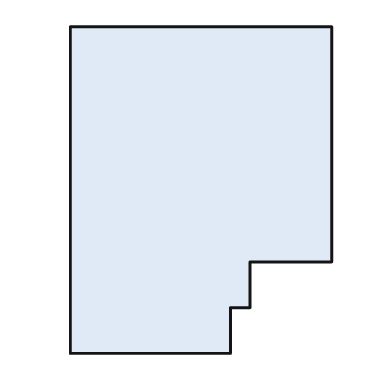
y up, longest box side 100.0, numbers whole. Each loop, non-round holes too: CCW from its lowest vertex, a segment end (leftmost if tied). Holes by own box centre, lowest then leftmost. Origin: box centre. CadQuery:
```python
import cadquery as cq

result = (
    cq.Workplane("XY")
    .moveTo(-40.0, -50.0)
    .lineTo(9.0, -50.0)
    .lineTo(9.0, -36.0)
    .lineTo(15.0, -36.0)
    .lineTo(15.0, -22.0)
    .lineTo(40.0, -22.0)
    .lineTo(40.0, 50.0)
    .lineTo(-40.0, 50.0)
    .close()
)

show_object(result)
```